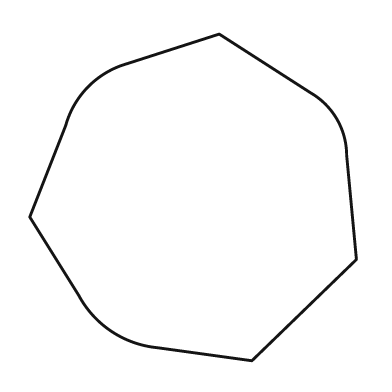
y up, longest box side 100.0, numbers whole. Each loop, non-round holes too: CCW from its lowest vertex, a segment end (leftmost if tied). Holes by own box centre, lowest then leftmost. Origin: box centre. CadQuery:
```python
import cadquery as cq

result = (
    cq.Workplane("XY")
    .moveTo(18.0, -50.0)
    .lineTo(50.0, -19.0)
    .lineTo(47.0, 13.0)
    .threePointArc((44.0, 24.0), (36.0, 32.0))
    .lineTo(8.0, 50.0)
    .lineTo(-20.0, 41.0)
    .threePointArc((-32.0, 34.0), (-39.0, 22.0))
    .lineTo(-50.0, -6.0)
    .lineTo(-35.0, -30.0)
    .threePointArc((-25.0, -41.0), (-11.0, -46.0))
    .close()
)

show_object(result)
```